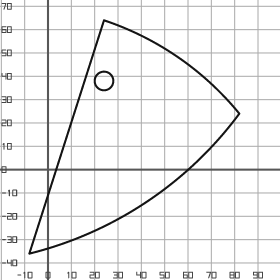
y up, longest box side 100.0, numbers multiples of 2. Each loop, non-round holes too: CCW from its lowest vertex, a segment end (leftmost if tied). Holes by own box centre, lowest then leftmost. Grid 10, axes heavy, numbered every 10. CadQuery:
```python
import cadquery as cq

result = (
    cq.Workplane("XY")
    .moveTo(-8.0, -36.0)
    .threePointArc((42.0, -14.0), (82.0, 24.0))
    .threePointArc((56.0, 48.0), (24.0, 64.0))
    .close()
    .moveTo(24.0, 38.0)
    .circle(4.0)
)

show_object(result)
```